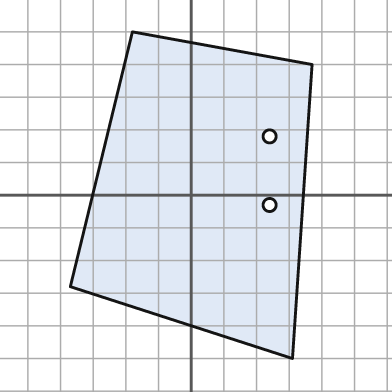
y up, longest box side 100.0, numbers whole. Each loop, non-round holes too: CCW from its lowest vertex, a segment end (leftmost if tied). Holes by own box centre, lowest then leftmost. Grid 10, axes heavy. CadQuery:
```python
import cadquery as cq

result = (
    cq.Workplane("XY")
    .moveTo(31.0, -50.0)
    .lineTo(37.0, 40.0)
    .lineTo(-18.0, 50.0)
    .lineTo(-37.0, -28.0)
    .close()
    .moveTo(24.0, -3.0)
    .circle(2.0)
    .moveTo(24.0, 18.0)
    .circle(2.0)
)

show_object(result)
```